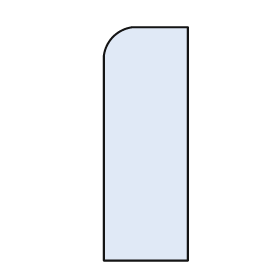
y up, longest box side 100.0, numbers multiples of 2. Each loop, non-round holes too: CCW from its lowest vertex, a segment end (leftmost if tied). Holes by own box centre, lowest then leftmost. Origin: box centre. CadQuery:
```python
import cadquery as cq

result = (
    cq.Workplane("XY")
    .moveTo(-18.0, -50.0)
    .lineTo(18.0, -50.0)
    .lineTo(18.0, 50.0)
    .lineTo(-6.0, 50.0)
    .threePointArc((-14.0, 46.0), (-18.0, 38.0))
    .close()
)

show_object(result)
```